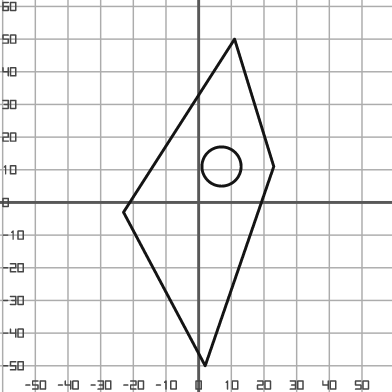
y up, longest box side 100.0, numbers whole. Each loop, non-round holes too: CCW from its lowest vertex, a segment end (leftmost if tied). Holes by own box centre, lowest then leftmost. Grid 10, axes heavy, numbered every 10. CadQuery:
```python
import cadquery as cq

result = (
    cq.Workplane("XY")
    .moveTo(2.0, -50.0)
    .lineTo(23.0, 11.0)
    .lineTo(11.0, 50.0)
    .lineTo(-23.0, -3.0)
    .close()
    .moveTo(7.0, 11.0)
    .circle(6.0)
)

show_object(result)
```